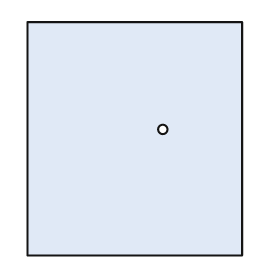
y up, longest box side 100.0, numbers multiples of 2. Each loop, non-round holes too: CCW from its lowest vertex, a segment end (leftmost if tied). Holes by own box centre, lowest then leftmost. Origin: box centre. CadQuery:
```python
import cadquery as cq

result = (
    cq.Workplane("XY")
    .moveTo(-46.0, -50.0)
    .lineTo(46.0, -50.0)
    .lineTo(46.0, 50.0)
    .lineTo(-46.0, 50.0)
    .close()
    .moveTo(12.0, 4.0)
    .circle(2.0)
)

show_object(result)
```